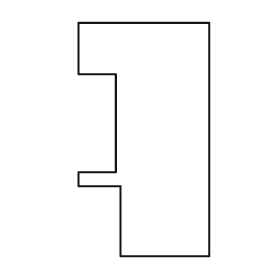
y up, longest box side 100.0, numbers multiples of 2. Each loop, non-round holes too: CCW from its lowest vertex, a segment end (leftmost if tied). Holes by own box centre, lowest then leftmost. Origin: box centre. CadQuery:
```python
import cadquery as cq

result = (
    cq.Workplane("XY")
    .moveTo(-10.0, -50.0)
    .lineTo(28.0, -50.0)
    .lineTo(28.0, 50.0)
    .lineTo(-28.0, 50.0)
    .lineTo(-28.0, 28.0)
    .lineTo(-12.0, 28.0)
    .lineTo(-12.0, -14.0)
    .lineTo(-28.0, -14.0)
    .lineTo(-28.0, -20.0)
    .lineTo(-10.0, -20.0)
    .close()
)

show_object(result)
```